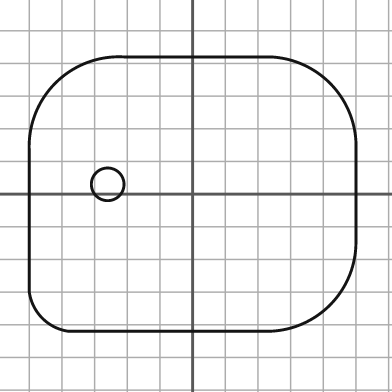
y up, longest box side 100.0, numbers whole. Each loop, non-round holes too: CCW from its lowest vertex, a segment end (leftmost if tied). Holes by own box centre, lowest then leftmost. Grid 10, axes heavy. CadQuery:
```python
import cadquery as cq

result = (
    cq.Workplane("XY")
    .moveTo(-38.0, -42.0)
    .lineTo(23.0, -42.0)
    .threePointArc((42.0, -34.0), (50.0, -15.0))
    .lineTo(50.0, 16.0)
    .threePointArc((42.0, 34.0), (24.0, 42.0))
    .lineTo(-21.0, 42.0)
    .threePointArc((-42.0, 34.0), (-50.0, 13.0))
    .lineTo(-50.0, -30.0)
    .threePointArc((-46.0, -38.0), (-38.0, -42.0))
    .close()
    .moveTo(-26.0, 3.0)
    .circle(5.0)
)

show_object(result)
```